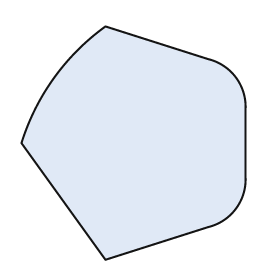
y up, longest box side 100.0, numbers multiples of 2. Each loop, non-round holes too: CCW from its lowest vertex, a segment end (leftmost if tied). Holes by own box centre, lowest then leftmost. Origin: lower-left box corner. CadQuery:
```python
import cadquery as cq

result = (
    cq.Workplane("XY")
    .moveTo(36.0, 0.0)
    .lineTo(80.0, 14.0)
    .threePointArc((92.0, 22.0), (96.0, 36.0))
    .lineTo(96.0, 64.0)
    .threePointArc((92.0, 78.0), (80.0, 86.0))
    .lineTo(36.0, 100.0)
    .threePointArc((14.0, 78.0), (0.0, 50.0))
    .close()
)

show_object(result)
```